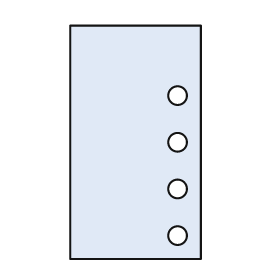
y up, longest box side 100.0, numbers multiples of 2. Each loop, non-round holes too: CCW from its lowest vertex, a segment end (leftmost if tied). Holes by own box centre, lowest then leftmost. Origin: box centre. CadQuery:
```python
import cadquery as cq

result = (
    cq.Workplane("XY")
    .moveTo(-28.0, -50.0)
    .lineTo(28.0, -50.0)
    .lineTo(28.0, 50.0)
    .lineTo(-28.0, 50.0)
    .close()
    .moveTo(18.0, -40.0)
    .circle(4.0)
    .moveTo(18.0, -20.0)
    .circle(4.0)
    .moveTo(18.0, 0.0)
    .circle(4.0)
    .moveTo(18.0, 20.0)
    .circle(4.0)
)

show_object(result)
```